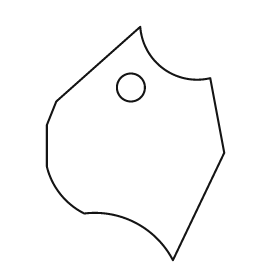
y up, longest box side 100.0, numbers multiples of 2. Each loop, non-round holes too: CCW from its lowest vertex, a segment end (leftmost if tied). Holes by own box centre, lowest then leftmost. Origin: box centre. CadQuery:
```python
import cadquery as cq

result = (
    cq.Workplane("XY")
    .moveTo(16.0, -50.0)
    .lineTo(38.0, -4.0)
    .lineTo(32.0, 28.0)
    .threePointArc((12.0, 32.0), (2.0, 50.0))
    .lineTo(-34.0, 18.0)
    .lineTo(-38.0, 8.0)
    .lineTo(-38.0, -10.0)
    .threePointArc((-32.0, -22.0), (-22.0, -30.0))
    .threePointArc((0.0, -34.0), (16.0, -50.0))
    .close()
    .moveTo(-2.0, 24.0)
    .circle(6.0)
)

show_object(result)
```